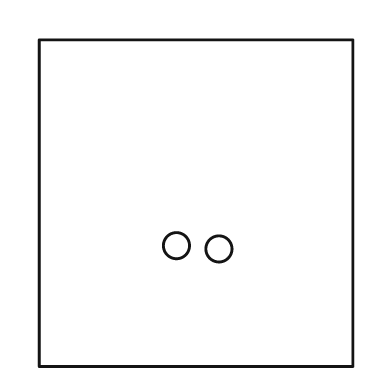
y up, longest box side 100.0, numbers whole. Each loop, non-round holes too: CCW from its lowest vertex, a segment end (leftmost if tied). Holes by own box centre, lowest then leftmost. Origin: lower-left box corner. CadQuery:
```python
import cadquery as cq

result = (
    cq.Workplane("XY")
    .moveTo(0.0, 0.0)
    .lineTo(96.0, 0.0)
    .lineTo(96.0, 100.0)
    .lineTo(0.0, 100.0)
    .close()
    .moveTo(55.0, 36.0)
    .circle(4.0)
    .moveTo(42.0, 37.0)
    .circle(4.0)
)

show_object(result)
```